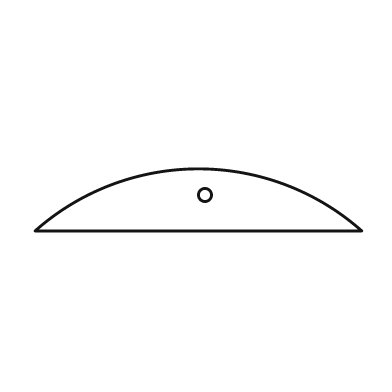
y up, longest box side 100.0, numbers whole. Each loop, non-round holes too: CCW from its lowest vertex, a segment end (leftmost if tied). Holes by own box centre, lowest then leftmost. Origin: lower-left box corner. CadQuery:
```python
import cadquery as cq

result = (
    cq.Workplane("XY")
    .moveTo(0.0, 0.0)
    .lineTo(100.0, 0.0)
    .threePointArc((50.0, 19.0), (0.0, 0.0))
    .close()
    .moveTo(52.0, 11.0)
    .circle(2.0)
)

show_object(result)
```